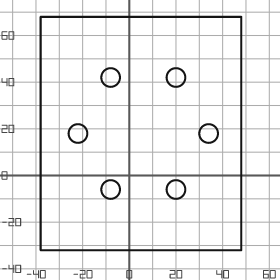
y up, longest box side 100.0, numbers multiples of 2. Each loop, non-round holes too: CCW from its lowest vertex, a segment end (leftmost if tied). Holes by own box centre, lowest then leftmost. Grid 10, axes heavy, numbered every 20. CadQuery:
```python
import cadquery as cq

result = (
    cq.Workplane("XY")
    .moveTo(-38.0, -32.0)
    .lineTo(48.0, -32.0)
    .lineTo(48.0, 68.0)
    .lineTo(-38.0, 68.0)
    .close()
    .moveTo(-8.0, -6.0)
    .circle(4.0)
    .moveTo(20.0, -6.0)
    .circle(4.0)
    .moveTo(-22.0, 18.0)
    .circle(4.0)
    .moveTo(34.0, 18.0)
    .circle(4.0)
    .moveTo(-8.0, 42.0)
    .circle(4.0)
    .moveTo(20.0, 42.0)
    .circle(4.0)
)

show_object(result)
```